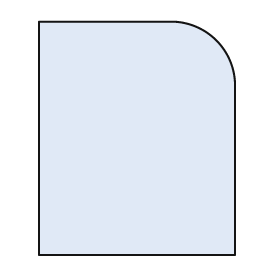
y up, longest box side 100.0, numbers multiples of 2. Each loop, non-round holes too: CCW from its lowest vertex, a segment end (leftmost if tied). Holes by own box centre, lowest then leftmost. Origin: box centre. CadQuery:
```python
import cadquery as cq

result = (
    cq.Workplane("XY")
    .moveTo(-42.0, -50.0)
    .lineTo(42.0, -50.0)
    .lineTo(42.0, 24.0)
    .threePointArc((34.0, 42.0), (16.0, 50.0))
    .lineTo(-42.0, 50.0)
    .close()
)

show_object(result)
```